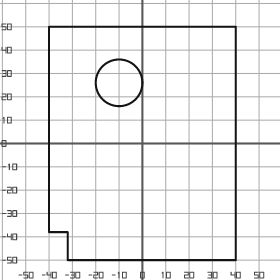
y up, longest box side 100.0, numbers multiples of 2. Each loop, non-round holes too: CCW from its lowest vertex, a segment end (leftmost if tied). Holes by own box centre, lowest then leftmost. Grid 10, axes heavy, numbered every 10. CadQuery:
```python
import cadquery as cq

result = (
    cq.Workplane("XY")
    .moveTo(-32.0, -50.0)
    .lineTo(40.0, -50.0)
    .lineTo(40.0, 50.0)
    .lineTo(-40.0, 50.0)
    .lineTo(-40.0, -38.0)
    .lineTo(-32.0, -38.0)
    .close()
    .moveTo(-10.0, 26.0)
    .circle(10.0)
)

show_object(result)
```